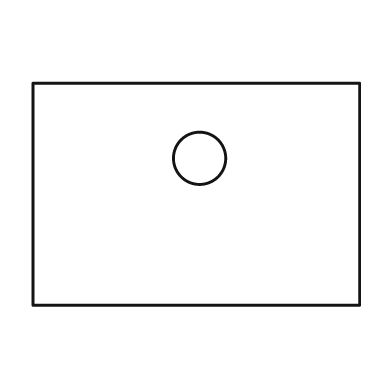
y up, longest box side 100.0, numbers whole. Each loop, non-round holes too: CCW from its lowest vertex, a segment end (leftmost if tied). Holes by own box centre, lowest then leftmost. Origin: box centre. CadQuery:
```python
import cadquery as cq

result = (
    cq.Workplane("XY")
    .moveTo(-50.0, -34.0)
    .lineTo(50.0, -34.0)
    .lineTo(50.0, 34.0)
    .lineTo(-50.0, 34.0)
    .close()
    .moveTo(1.0, 11.0)
    .circle(8.0)
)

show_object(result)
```